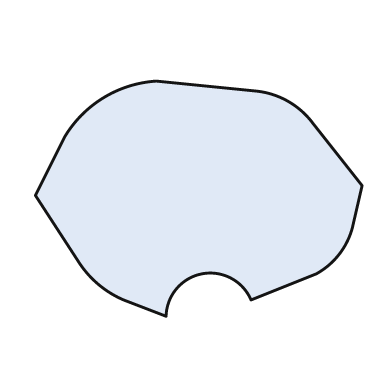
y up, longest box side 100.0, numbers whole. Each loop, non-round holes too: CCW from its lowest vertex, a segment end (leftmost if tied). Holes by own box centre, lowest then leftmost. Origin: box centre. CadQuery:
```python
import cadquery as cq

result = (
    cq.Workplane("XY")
    .moveTo(-10.0, -36.0)
    .threePointArc((1.0, -23.0), (16.0, -31.0))
    .lineTo(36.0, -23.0)
    .threePointArc((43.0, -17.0), (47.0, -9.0))
    .lineTo(50.0, 4.0)
    .lineTo(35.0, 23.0)
    .threePointArc((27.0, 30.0), (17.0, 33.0))
    .lineTo(-13.0, 36.0)
    .threePointArc((-29.0, 31.0), (-41.0, 19.0))
    .lineTo(-50.0, 1.0)
    .lineTo(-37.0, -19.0)
    .threePointArc((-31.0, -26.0), (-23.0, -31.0))
    .close()
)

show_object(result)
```